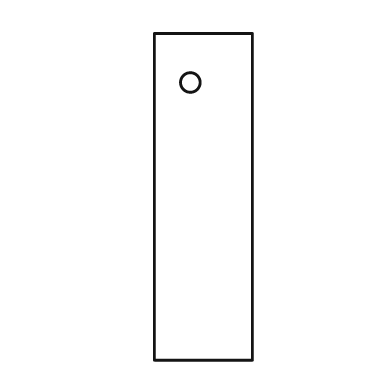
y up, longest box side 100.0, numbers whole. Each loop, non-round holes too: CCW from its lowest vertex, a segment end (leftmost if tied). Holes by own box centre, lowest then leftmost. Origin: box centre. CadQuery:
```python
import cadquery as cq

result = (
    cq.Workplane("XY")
    .moveTo(-15.0, -50.0)
    .lineTo(15.0, -50.0)
    .lineTo(15.0, 50.0)
    .lineTo(-15.0, 50.0)
    .close()
    .moveTo(-4.0, 35.0)
    .circle(3.0)
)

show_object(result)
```